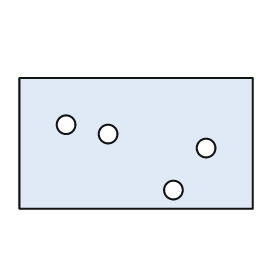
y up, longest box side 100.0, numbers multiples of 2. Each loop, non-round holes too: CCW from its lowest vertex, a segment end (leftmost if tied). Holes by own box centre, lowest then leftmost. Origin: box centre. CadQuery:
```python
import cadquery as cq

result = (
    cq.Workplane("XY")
    .moveTo(-50.0, -28.0)
    .lineTo(50.0, -28.0)
    .lineTo(50.0, 28.0)
    .lineTo(-50.0, 28.0)
    .close()
    .moveTo(16.0, -20.0)
    .circle(4.0)
    .moveTo(30.0, -2.0)
    .circle(4.0)
    .moveTo(-12.0, 4.0)
    .circle(4.0)
    .moveTo(-30.0, 8.0)
    .circle(4.0)
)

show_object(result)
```